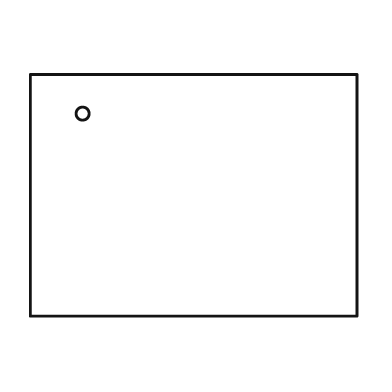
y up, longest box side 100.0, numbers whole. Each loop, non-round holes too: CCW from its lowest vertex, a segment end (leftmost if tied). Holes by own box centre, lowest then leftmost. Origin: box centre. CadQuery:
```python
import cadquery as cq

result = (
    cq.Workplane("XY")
    .moveTo(-50.0, -37.0)
    .lineTo(50.0, -37.0)
    .lineTo(50.0, 37.0)
    .lineTo(-50.0, 37.0)
    .close()
    .moveTo(-34.0, 25.0)
    .circle(2.0)
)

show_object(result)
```